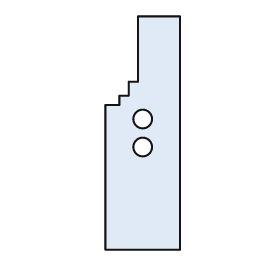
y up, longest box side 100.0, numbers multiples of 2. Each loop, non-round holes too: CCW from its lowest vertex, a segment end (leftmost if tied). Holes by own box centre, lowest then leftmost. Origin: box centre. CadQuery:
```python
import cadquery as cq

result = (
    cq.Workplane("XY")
    .moveTo(-16.0, -50.0)
    .lineTo(16.0, -50.0)
    .lineTo(16.0, 50.0)
    .lineTo(-2.0, 50.0)
    .lineTo(-2.0, 22.0)
    .lineTo(-6.0, 22.0)
    .lineTo(-6.0, 16.0)
    .lineTo(-10.0, 16.0)
    .lineTo(-10.0, 12.0)
    .lineTo(-16.0, 12.0)
    .close()
    .moveTo(0.0, -6.0)
    .circle(4.0)
    .moveTo(0.0, 6.0)
    .circle(4.0)
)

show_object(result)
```